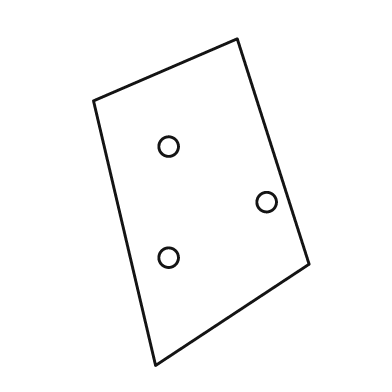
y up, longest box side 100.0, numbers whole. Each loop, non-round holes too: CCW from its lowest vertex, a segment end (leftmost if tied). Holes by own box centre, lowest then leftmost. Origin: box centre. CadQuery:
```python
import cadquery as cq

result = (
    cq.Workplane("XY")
    .moveTo(-14.0, -50.0)
    .lineTo(33.0, -19.0)
    .lineTo(11.0, 50.0)
    .lineTo(-33.0, 31.0)
    .close()
    .moveTo(-10.0, -17.0)
    .circle(3.0)
    .moveTo(20.0, 0.0)
    .circle(3.0)
    .moveTo(-10.0, 17.0)
    .circle(3.0)
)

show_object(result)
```